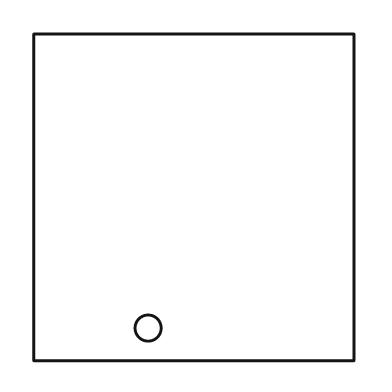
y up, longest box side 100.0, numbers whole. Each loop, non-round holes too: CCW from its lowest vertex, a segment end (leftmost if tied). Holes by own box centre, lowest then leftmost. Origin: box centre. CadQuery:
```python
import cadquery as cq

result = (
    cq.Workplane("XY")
    .moveTo(-49.0, -50.0)
    .lineTo(49.0, -50.0)
    .lineTo(49.0, 50.0)
    .lineTo(-49.0, 50.0)
    .close()
    .moveTo(-14.0, -40.0)
    .circle(4.0)
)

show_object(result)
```